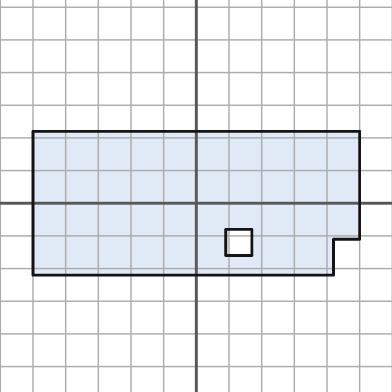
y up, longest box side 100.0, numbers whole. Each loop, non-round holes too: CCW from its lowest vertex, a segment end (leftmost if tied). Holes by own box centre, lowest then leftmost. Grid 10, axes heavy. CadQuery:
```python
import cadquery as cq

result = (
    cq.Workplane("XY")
    .moveTo(-50.0, -22.0)
    .lineTo(42.0, -22.0)
    .lineTo(42.0, -11.0)
    .lineTo(50.0, -11.0)
    .lineTo(50.0, 22.0)
    .lineTo(-50.0, 22.0)
    .close()
    .moveTo(9.0, -16.0)
    .lineTo(17.0, -16.0)
    .lineTo(17.0, -8.0)
    .lineTo(9.0, -8.0)
    .close()
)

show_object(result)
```